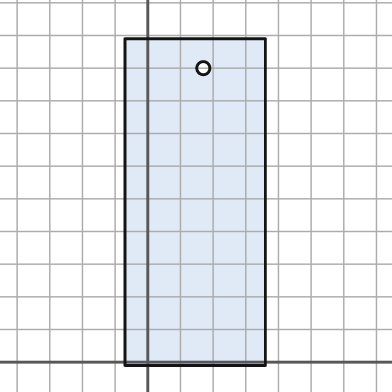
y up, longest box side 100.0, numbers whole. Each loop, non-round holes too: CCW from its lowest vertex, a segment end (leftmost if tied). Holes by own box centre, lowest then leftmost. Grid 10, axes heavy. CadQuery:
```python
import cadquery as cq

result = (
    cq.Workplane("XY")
    .moveTo(-7.0, -1.0)
    .lineTo(36.0, -1.0)
    .lineTo(36.0, 99.0)
    .lineTo(-7.0, 99.0)
    .close()
    .moveTo(17.0, 90.0)
    .circle(2.0)
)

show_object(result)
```